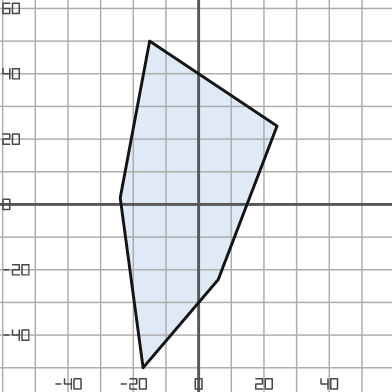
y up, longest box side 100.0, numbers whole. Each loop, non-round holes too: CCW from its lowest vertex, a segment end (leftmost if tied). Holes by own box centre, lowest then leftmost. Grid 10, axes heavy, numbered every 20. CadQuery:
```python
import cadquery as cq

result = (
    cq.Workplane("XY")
    .moveTo(-17.0, -50.0)
    .lineTo(6.0, -23.0)
    .lineTo(24.0, 24.0)
    .lineTo(-15.0, 50.0)
    .lineTo(-24.0, 2.0)
    .close()
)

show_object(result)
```